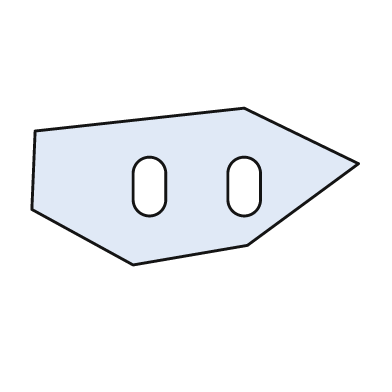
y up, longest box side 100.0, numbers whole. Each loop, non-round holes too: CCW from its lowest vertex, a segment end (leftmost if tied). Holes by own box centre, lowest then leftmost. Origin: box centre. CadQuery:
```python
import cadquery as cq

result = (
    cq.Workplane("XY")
    .moveTo(-19.0, -24.0)
    .lineTo(16.0, -18.0)
    .lineTo(50.0, 7.0)
    .lineTo(15.0, 24.0)
    .lineTo(-49.0, 17.0)
    .lineTo(-50.0, -7.0)
    .close()
    .moveTo(-19.0, -4.0)
    .threePointArc((-14.0, -9.0), (-9.0, -4.0))
    .lineTo(-9.0, 4.0)
    .threePointArc((-14.0, 9.0), (-19.0, 4.0))
    .close()
    .moveTo(10.0, -4.0)
    .threePointArc((15.0, -9.0), (20.0, -4.0))
    .lineTo(20.0, 4.0)
    .threePointArc((15.0, 9.0), (10.0, 4.0))
    .close()
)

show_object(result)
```